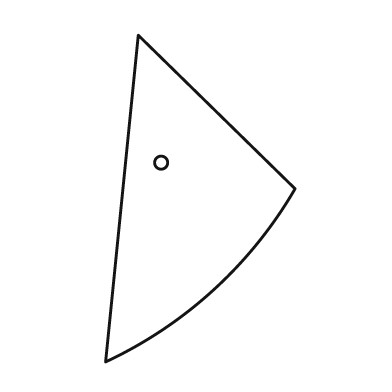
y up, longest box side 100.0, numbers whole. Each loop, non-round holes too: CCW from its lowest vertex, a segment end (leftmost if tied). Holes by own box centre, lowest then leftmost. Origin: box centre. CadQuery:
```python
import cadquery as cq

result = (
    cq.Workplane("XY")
    .moveTo(-29.0, -50.0)
    .threePointArc((4.0, -28.0), (29.0, 3.0))
    .lineTo(-19.0, 50.0)
    .close()
    .moveTo(-12.0, 11.0)
    .circle(2.0)
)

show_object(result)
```